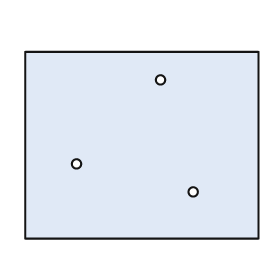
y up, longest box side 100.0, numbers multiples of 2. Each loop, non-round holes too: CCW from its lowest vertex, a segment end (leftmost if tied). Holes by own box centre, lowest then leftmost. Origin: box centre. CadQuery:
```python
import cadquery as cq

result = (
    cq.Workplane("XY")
    .moveTo(-50.0, -40.0)
    .lineTo(50.0, -40.0)
    .lineTo(50.0, 40.0)
    .lineTo(-50.0, 40.0)
    .close()
    .moveTo(22.0, -20.0)
    .circle(2.0)
    .moveTo(-28.0, -8.0)
    .circle(2.0)
    .moveTo(8.0, 28.0)
    .circle(2.0)
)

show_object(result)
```